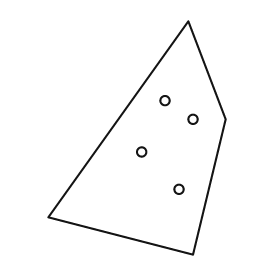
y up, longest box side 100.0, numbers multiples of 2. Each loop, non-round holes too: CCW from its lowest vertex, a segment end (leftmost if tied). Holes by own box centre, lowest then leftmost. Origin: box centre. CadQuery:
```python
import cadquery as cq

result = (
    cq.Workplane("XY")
    .moveTo(24.0, -50.0)
    .lineTo(38.0, 8.0)
    .lineTo(22.0, 50.0)
    .lineTo(-38.0, -34.0)
    .close()
    .moveTo(18.0, -22.0)
    .circle(2.0)
    .moveTo(2.0, -6.0)
    .circle(2.0)
    .moveTo(24.0, 8.0)
    .circle(2.0)
    .moveTo(12.0, 16.0)
    .circle(2.0)
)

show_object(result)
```